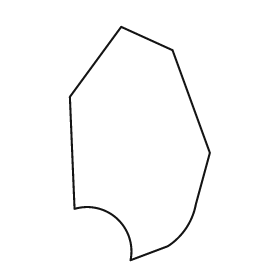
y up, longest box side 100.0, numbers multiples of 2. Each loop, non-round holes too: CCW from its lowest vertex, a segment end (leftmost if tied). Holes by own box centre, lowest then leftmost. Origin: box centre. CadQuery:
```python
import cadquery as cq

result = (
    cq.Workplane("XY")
    .moveTo(-4.0, -50.0)
    .lineTo(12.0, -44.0)
    .threePointArc((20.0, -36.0), (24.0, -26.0))
    .lineTo(30.0, -4.0)
    .lineTo(14.0, 40.0)
    .lineTo(-8.0, 50.0)
    .lineTo(-30.0, 20.0)
    .lineTo(-28.0, -28.0)
    .threePointArc((-10.0, -32.0), (-4.0, -50.0))
    .close()
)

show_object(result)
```